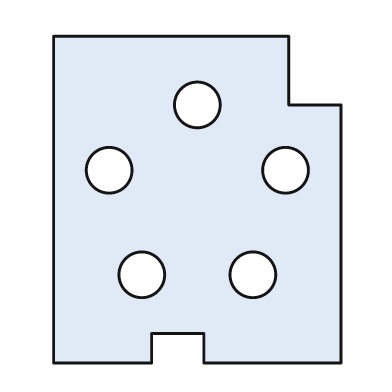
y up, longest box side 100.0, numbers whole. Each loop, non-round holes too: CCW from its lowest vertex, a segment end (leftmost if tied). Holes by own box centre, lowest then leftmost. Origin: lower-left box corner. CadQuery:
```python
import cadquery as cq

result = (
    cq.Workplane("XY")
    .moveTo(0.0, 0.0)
    .lineTo(30.0, 0.0)
    .lineTo(30.0, 9.0)
    .lineTo(46.0, 9.0)
    .lineTo(46.0, 0.0)
    .lineTo(88.0, 0.0)
    .lineTo(88.0, 79.0)
    .lineTo(72.0, 79.0)
    .lineTo(72.0, 100.0)
    .lineTo(0.0, 100.0)
    .close()
    .moveTo(27.0, 27.0)
    .circle(7.0)
    .moveTo(61.0, 27.0)
    .circle(7.0)
    .moveTo(17.0, 59.0)
    .circle(7.0)
    .moveTo(71.0, 59.0)
    .circle(7.0)
    .moveTo(44.0, 79.0)
    .circle(7.0)
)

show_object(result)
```